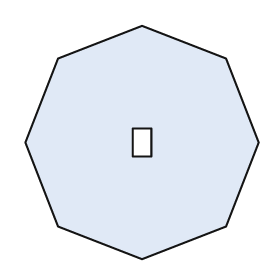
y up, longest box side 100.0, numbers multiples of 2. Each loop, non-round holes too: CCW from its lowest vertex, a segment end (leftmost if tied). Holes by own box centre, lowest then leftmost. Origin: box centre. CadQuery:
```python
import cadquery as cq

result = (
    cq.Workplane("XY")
    .moveTo(0.0, -50.0)
    .lineTo(36.0, -36.0)
    .lineTo(50.0, 0.0)
    .lineTo(36.0, 36.0)
    .lineTo(0.0, 50.0)
    .lineTo(-36.0, 36.0)
    .lineTo(-50.0, 0.0)
    .lineTo(-36.0, -36.0)
    .close()
    .moveTo(-4.0, -6.0)
    .lineTo(4.0, -6.0)
    .lineTo(4.0, 6.0)
    .lineTo(-4.0, 6.0)
    .close()
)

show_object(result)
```